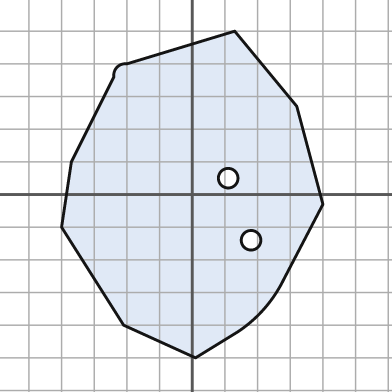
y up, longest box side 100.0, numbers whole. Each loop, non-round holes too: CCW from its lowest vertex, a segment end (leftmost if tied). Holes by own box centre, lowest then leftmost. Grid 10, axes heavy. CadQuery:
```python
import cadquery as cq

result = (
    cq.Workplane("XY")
    .moveTo(1.0, -50.0)
    .lineTo(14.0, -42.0)
    .threePointArc((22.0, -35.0), (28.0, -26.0))
    .lineTo(40.0, -3.0)
    .lineTo(32.0, 27.0)
    .lineTo(13.0, 50.0)
    .lineTo(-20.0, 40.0)
    .threePointArc((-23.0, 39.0), (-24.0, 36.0))
    .lineTo(-37.0, 10.0)
    .lineTo(-40.0, -10.0)
    .lineTo(-21.0, -40.0)
    .close()
    .moveTo(18.0, -14.0)
    .circle(3.0)
    .moveTo(11.0, 5.0)
    .circle(3.0)
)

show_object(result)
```